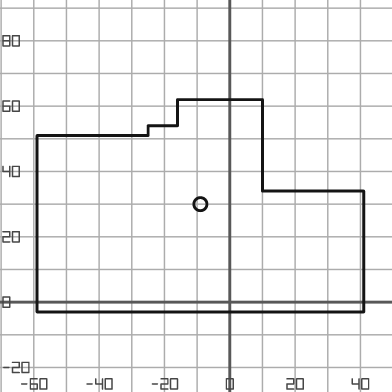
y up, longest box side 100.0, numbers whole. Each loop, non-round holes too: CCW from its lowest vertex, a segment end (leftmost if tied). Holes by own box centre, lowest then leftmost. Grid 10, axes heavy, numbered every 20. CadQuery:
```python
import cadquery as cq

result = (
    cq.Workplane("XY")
    .moveTo(-59.0, -3.0)
    .lineTo(41.0, -3.0)
    .lineTo(41.0, 34.0)
    .lineTo(10.0, 34.0)
    .lineTo(10.0, 62.0)
    .lineTo(-16.0, 62.0)
    .lineTo(-16.0, 54.0)
    .lineTo(-25.0, 54.0)
    .lineTo(-25.0, 51.0)
    .lineTo(-59.0, 51.0)
    .close()
    .moveTo(-9.0, 30.0)
    .circle(2.0)
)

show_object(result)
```